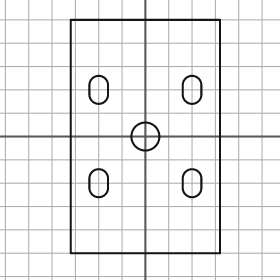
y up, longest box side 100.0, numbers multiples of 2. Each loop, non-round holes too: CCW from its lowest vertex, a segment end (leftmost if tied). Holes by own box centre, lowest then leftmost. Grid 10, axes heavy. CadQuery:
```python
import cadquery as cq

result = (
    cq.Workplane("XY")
    .moveTo(-32.0, -50.0)
    .lineTo(32.0, -50.0)
    .lineTo(32.0, 50.0)
    .lineTo(-32.0, 50.0)
    .close()
    .moveTo(-24.0, -22.0)
    .threePointArc((-20.0, -26.0), (-16.0, -22.0))
    .lineTo(-16.0, -18.0)
    .threePointArc((-20.0, -14.0), (-24.0, -18.0))
    .close()
    .moveTo(16.0, -22.0)
    .threePointArc((20.0, -26.0), (24.0, -22.0))
    .lineTo(24.0, -18.0)
    .threePointArc((20.0, -14.0), (16.0, -18.0))
    .close()
    .moveTo(0.0, 0.0)
    .circle(6.0)
    .moveTo(-24.0, 18.0)
    .threePointArc((-20.0, 14.0), (-16.0, 18.0))
    .lineTo(-16.0, 22.0)
    .threePointArc((-20.0, 26.0), (-24.0, 22.0))
    .close()
    .moveTo(16.0, 18.0)
    .threePointArc((20.0, 14.0), (24.0, 18.0))
    .lineTo(24.0, 22.0)
    .threePointArc((20.0, 26.0), (16.0, 22.0))
    .close()
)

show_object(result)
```